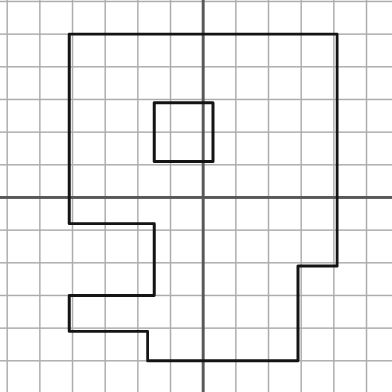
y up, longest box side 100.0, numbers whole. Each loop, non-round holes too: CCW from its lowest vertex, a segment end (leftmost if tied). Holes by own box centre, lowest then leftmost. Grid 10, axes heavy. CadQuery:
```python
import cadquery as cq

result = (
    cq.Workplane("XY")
    .moveTo(-17.0, -50.0)
    .lineTo(29.0, -50.0)
    .lineTo(29.0, -21.0)
    .lineTo(41.0, -21.0)
    .lineTo(41.0, 50.0)
    .lineTo(-41.0, 50.0)
    .lineTo(-41.0, -8.0)
    .lineTo(-15.0, -8.0)
    .lineTo(-15.0, -30.0)
    .lineTo(-41.0, -30.0)
    .lineTo(-41.0, -41.0)
    .lineTo(-17.0, -41.0)
    .close()
    .moveTo(-15.0, 11.0)
    .lineTo(3.0, 11.0)
    .lineTo(3.0, 29.0)
    .lineTo(-15.0, 29.0)
    .close()
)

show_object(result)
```